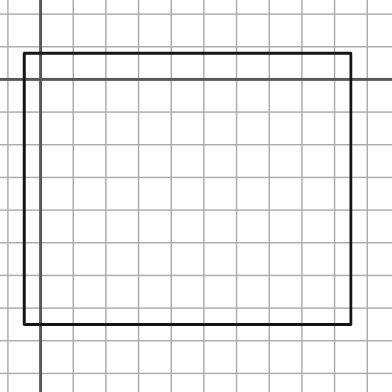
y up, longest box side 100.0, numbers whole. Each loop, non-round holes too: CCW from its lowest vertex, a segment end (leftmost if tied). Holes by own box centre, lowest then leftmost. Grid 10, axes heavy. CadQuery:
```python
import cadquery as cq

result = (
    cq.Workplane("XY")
    .moveTo(-5.0, -75.0)
    .lineTo(95.0, -75.0)
    .lineTo(95.0, 8.0)
    .lineTo(-5.0, 8.0)
    .close()
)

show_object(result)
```